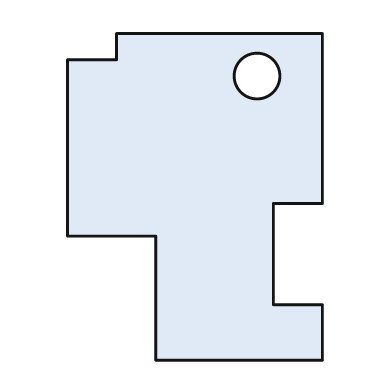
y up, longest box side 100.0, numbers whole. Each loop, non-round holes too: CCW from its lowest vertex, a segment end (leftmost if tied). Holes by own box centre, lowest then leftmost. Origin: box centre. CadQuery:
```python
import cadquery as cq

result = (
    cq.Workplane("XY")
    .moveTo(-12.0, -50.0)
    .lineTo(39.0, -50.0)
    .lineTo(39.0, -33.0)
    .lineTo(24.0, -33.0)
    .lineTo(24.0, -2.0)
    .lineTo(39.0, -2.0)
    .lineTo(39.0, 50.0)
    .lineTo(-24.0, 50.0)
    .lineTo(-24.0, 42.0)
    .lineTo(-39.0, 42.0)
    .lineTo(-39.0, -12.0)
    .lineTo(-12.0, -12.0)
    .close()
    .moveTo(19.0, 37.0)
    .circle(7.0)
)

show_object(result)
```